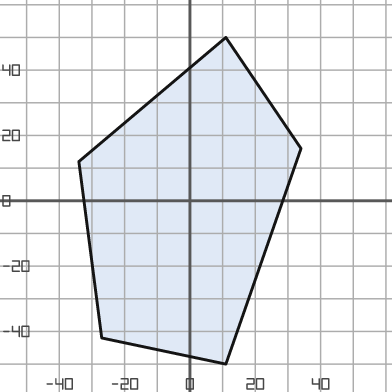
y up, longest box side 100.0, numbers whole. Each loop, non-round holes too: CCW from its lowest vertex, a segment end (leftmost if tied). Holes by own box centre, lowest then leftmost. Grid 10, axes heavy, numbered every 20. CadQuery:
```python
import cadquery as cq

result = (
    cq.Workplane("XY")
    .moveTo(11.0, -50.0)
    .lineTo(34.0, 16.0)
    .lineTo(11.0, 50.0)
    .lineTo(-34.0, 12.0)
    .lineTo(-27.0, -42.0)
    .close()
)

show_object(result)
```